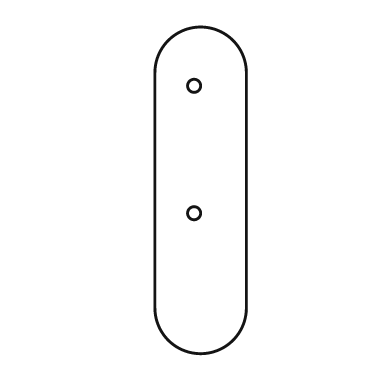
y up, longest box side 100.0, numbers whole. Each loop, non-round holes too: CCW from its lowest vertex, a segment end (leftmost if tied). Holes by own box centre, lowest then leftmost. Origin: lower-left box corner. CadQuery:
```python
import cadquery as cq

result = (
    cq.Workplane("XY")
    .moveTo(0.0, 14.0)
    .threePointArc((14.0, 0.0), (28.0, 14.0))
    .lineTo(28.0, 86.0)
    .threePointArc((14.0, 100.0), (0.0, 86.0))
    .close()
    .moveTo(12.0, 43.0)
    .circle(2.0)
    .moveTo(12.0, 82.0)
    .circle(2.0)
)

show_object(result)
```